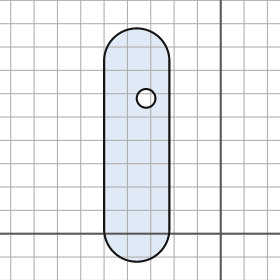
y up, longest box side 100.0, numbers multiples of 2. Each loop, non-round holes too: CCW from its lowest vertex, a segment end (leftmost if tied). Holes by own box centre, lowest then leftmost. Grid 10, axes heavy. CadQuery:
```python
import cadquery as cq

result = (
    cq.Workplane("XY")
    .moveTo(-50.0, 2.0)
    .threePointArc((-36.0, -12.0), (-22.0, 2.0))
    .lineTo(-22.0, 74.0)
    .threePointArc((-36.0, 88.0), (-50.0, 74.0))
    .close()
    .moveTo(-32.0, 58.0)
    .circle(4.0)
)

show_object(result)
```